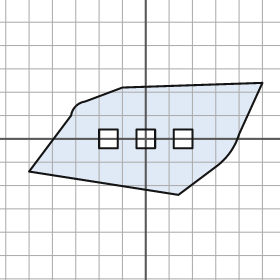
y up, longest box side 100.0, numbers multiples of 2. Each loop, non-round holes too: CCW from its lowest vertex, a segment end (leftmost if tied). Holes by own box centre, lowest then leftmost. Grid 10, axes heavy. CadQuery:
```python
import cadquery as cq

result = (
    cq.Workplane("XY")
    .moveTo(14.0, -24.0)
    .lineTo(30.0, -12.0)
    .threePointArc((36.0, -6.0), (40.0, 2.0))
    .lineTo(50.0, 24.0)
    .lineTo(-10.0, 22.0)
    .lineTo(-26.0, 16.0)
    .threePointArc((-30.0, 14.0), (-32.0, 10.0))
    .lineTo(-50.0, -14.0)
    .close()
    .moveTo(-20.0, -4.0)
    .lineTo(-12.0, -4.0)
    .lineTo(-12.0, 4.0)
    .lineTo(-20.0, 4.0)
    .close()
    .moveTo(-4.0, -4.0)
    .lineTo(4.0, -4.0)
    .lineTo(4.0, 4.0)
    .lineTo(-4.0, 4.0)
    .close()
    .moveTo(12.0, -4.0)
    .lineTo(20.0, -4.0)
    .lineTo(20.0, 4.0)
    .lineTo(12.0, 4.0)
    .close()
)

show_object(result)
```